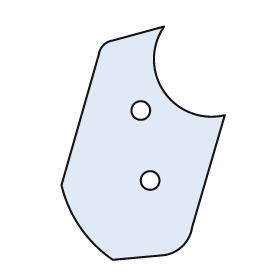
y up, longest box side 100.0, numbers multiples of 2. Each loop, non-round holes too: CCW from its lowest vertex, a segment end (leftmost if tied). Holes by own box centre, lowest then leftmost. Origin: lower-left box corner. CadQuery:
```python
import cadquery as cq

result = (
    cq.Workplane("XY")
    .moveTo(22.0, 0.0)
    .lineTo(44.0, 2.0)
    .threePointArc((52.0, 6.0), (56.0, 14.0))
    .lineTo(70.0, 62.0)
    .threePointArc((44.0, 72.0), (44.0, 100.0))
    .lineTo(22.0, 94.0)
    .threePointArc((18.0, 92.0), (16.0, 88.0))
    .lineTo(0.0, 32.0)
    .threePointArc((8.0, 14.0), (22.0, 0.0))
    .close()
    .moveTo(38.0, 34.0)
    .circle(4.0)
    .moveTo(34.0, 64.0)
    .circle(4.0)
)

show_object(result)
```